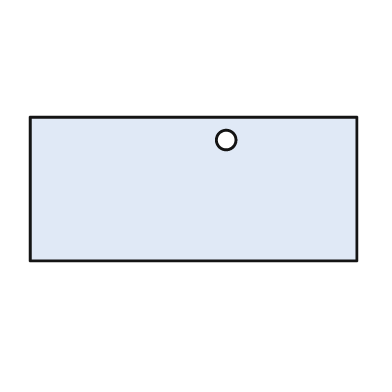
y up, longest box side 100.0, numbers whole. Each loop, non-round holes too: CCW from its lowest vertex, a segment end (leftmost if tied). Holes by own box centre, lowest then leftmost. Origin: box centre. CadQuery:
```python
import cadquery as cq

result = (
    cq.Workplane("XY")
    .moveTo(-50.0, -22.0)
    .lineTo(50.0, -22.0)
    .lineTo(50.0, 22.0)
    .lineTo(-50.0, 22.0)
    .close()
    .moveTo(10.0, 15.0)
    .circle(3.0)
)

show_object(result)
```